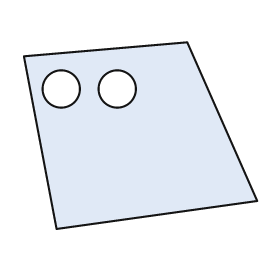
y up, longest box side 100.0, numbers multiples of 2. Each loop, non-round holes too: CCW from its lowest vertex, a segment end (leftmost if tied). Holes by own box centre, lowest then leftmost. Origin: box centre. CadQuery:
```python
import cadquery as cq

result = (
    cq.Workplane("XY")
    .moveTo(-36.0, -40.0)
    .lineTo(50.0, -28.0)
    .lineTo(20.0, 40.0)
    .lineTo(-50.0, 34.0)
    .close()
    .moveTo(-34.0, 20.0)
    .circle(8.0)
    .moveTo(-10.0, 20.0)
    .circle(8.0)
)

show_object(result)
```